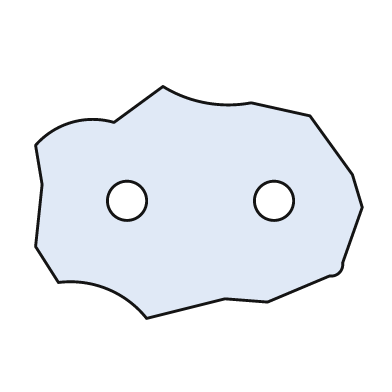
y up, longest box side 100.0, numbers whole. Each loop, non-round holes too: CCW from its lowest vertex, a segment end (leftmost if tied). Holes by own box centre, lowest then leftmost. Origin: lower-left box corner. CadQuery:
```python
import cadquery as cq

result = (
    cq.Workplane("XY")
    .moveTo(34.0, 0.0)
    .lineTo(58.0, 6.0)
    .lineTo(71.0, 5.0)
    .lineTo(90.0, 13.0)
    .threePointArc((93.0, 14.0), (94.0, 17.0))
    .lineTo(100.0, 34.0)
    .lineTo(97.0, 44.0)
    .lineTo(84.0, 62.0)
    .lineTo(66.0, 66.0)
    .threePointArc((52.0, 66.0), (39.0, 71.0))
    .lineTo(24.0, 60.0)
    .threePointArc((11.0, 60.0), (0.0, 53.0))
    .lineTo(2.0, 41.0)
    .lineTo(0.0, 22.0)
    .lineTo(7.0, 11.0)
    .threePointArc((22.0, 9.0), (34.0, 0.0))
    .close()
    .moveTo(28.0, 36.0)
    .circle(6.0)
    .moveTo(73.0, 36.0)
    .circle(6.0)
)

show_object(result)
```